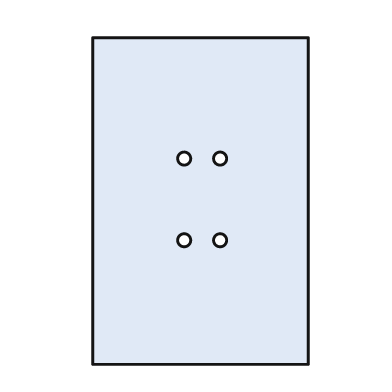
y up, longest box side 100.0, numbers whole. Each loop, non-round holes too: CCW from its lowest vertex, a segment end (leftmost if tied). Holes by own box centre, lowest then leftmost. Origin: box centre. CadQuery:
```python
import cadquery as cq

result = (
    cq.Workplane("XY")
    .moveTo(-33.0, -50.0)
    .lineTo(33.0, -50.0)
    .lineTo(33.0, 50.0)
    .lineTo(-33.0, 50.0)
    .close()
    .moveTo(-5.0, -12.0)
    .circle(2.0)
    .moveTo(6.0, -12.0)
    .circle(2.0)
    .moveTo(-5.0, 13.0)
    .circle(2.0)
    .moveTo(6.0, 13.0)
    .circle(2.0)
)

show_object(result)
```